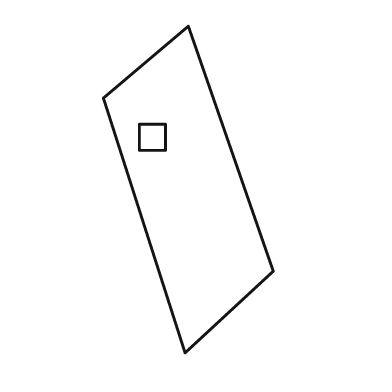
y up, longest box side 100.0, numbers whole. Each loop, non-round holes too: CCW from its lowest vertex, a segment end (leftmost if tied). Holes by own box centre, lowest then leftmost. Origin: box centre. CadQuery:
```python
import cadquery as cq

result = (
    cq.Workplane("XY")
    .moveTo(-1.0, -50.0)
    .lineTo(26.0, -25.0)
    .lineTo(0.0, 50.0)
    .lineTo(-26.0, 28.0)
    .close()
    .moveTo(-15.0, 12.0)
    .lineTo(-7.0, 12.0)
    .lineTo(-7.0, 20.0)
    .lineTo(-15.0, 20.0)
    .close()
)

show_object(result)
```